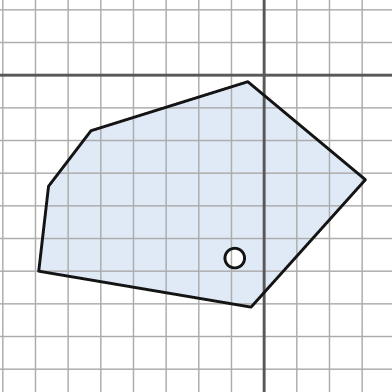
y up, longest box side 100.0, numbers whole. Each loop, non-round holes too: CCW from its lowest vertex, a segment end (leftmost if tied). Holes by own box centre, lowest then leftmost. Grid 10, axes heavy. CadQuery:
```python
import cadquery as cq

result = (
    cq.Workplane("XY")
    .moveTo(-4.0, -71.0)
    .lineTo(31.0, -32.0)
    .lineTo(-5.0, -2.0)
    .lineTo(-53.0, -17.0)
    .lineTo(-66.0, -34.0)
    .lineTo(-69.0, -60.0)
    .close()
    .moveTo(-9.0, -56.0)
    .circle(3.0)
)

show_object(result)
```